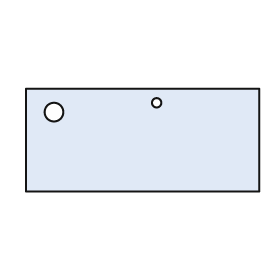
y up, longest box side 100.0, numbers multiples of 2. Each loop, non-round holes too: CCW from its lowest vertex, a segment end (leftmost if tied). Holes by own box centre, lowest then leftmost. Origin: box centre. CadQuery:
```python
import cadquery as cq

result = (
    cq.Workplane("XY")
    .moveTo(-50.0, -22.0)
    .lineTo(50.0, -22.0)
    .lineTo(50.0, 22.0)
    .lineTo(-50.0, 22.0)
    .close()
    .moveTo(-38.0, 12.0)
    .circle(4.0)
    .moveTo(6.0, 16.0)
    .circle(2.0)
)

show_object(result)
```